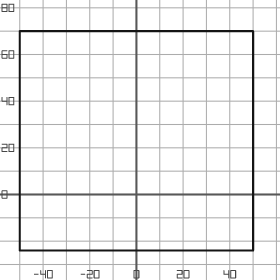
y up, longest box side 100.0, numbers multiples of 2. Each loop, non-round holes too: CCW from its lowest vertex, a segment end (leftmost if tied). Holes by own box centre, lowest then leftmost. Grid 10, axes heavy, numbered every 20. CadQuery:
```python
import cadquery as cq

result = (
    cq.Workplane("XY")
    .moveTo(-50.0, -24.0)
    .lineTo(50.0, -24.0)
    .lineTo(50.0, 70.0)
    .lineTo(-50.0, 70.0)
    .close()
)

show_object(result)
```